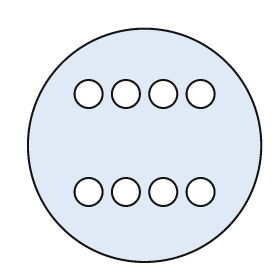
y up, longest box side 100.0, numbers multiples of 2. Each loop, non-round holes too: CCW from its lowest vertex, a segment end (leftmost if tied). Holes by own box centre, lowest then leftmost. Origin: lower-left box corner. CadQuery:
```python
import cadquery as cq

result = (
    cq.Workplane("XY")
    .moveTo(50.0, 50.0)
    .circle(50.0)
    .moveTo(26.0, 30.0)
    .circle(6.0)
    .moveTo(42.0, 30.0)
    .circle(6.0)
    .moveTo(58.0, 30.0)
    .circle(6.0)
    .moveTo(74.0, 30.0)
    .circle(6.0)
    .moveTo(26.0, 72.0)
    .circle(6.0)
    .moveTo(42.0, 72.0)
    .circle(6.0)
    .moveTo(58.0, 72.0)
    .circle(6.0)
    .moveTo(74.0, 72.0)
    .circle(6.0)
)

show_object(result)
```